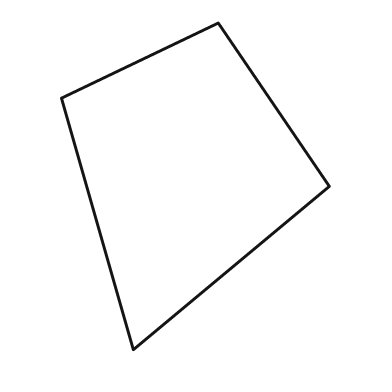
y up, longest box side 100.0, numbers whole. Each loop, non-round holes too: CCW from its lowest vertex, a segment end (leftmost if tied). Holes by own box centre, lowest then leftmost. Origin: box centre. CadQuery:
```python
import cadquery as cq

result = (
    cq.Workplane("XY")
    .moveTo(-19.0, -50.0)
    .lineTo(41.0, 0.0)
    .lineTo(7.0, 50.0)
    .lineTo(-41.0, 27.0)
    .close()
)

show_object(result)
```